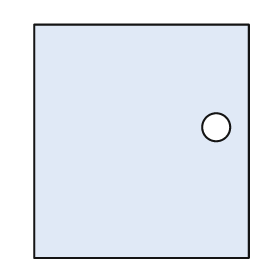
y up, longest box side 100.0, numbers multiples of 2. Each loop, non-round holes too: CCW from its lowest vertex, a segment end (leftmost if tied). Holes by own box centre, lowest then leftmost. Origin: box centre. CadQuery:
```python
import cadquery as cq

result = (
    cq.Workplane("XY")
    .moveTo(-46.0, -50.0)
    .lineTo(46.0, -50.0)
    .lineTo(46.0, 50.0)
    .lineTo(-46.0, 50.0)
    .close()
    .moveTo(32.0, 6.0)
    .circle(6.0)
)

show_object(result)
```